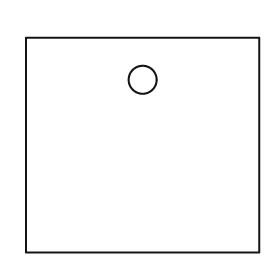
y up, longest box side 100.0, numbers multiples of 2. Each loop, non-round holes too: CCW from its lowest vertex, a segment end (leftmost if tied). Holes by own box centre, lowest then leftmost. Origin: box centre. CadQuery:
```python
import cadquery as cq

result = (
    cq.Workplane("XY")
    .moveTo(-50.0, -46.0)
    .lineTo(50.0, -46.0)
    .lineTo(50.0, 46.0)
    .lineTo(-50.0, 46.0)
    .close()
    .moveTo(0.0, 28.0)
    .circle(6.0)
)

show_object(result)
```